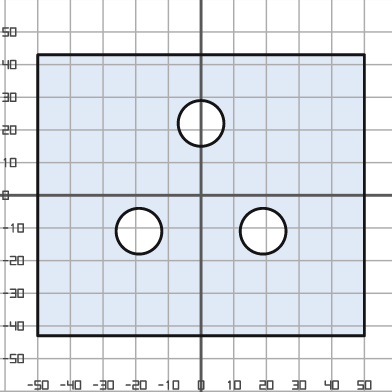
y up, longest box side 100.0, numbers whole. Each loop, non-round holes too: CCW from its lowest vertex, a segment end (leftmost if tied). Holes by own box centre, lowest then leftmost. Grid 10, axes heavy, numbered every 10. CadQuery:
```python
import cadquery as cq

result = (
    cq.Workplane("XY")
    .moveTo(-50.0, -43.0)
    .lineTo(50.0, -43.0)
    .lineTo(50.0, 43.0)
    .lineTo(-50.0, 43.0)
    .close()
    .moveTo(-19.0, -11.0)
    .circle(7.0)
    .moveTo(19.0, -11.0)
    .circle(7.0)
    .moveTo(0.0, 22.0)
    .circle(7.0)
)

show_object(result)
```